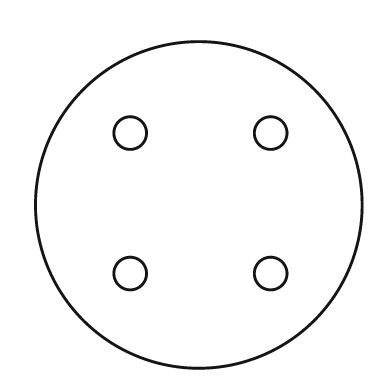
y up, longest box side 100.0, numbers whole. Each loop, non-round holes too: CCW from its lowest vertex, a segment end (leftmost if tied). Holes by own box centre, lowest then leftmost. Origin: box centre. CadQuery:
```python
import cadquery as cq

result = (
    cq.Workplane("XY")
    .moveTo(0.0, 0.0)
    .circle(50.0)
    .moveTo(-21.0, -21.0)
    .circle(5.0)
    .moveTo(22.0, -21.0)
    .circle(5.0)
    .moveTo(-21.0, 22.0)
    .circle(5.0)
    .moveTo(22.0, 22.0)
    .circle(5.0)
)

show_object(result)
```